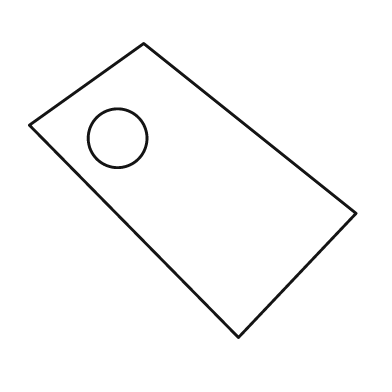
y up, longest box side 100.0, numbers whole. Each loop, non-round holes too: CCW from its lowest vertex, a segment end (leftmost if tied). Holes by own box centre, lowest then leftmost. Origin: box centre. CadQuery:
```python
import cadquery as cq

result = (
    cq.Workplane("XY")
    .moveTo(14.0, -45.0)
    .lineTo(50.0, -7.0)
    .lineTo(-15.0, 45.0)
    .lineTo(-50.0, 20.0)
    .close()
    .moveTo(-23.0, 16.0)
    .circle(9.0)
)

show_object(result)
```